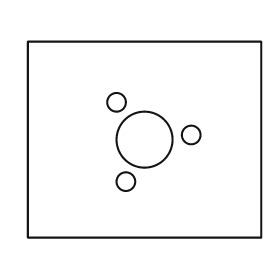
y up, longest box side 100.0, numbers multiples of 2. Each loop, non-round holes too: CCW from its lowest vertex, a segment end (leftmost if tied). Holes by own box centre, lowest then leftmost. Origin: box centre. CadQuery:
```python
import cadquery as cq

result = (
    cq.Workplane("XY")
    .moveTo(-50.0, -42.0)
    .lineTo(50.0, -42.0)
    .lineTo(50.0, 42.0)
    .lineTo(-50.0, 42.0)
    .close()
    .moveTo(-8.0, -18.0)
    .circle(4.0)
    .moveTo(0.0, 0.0)
    .circle(12.0)
    .moveTo(20.0, 2.0)
    .circle(4.0)
    .moveTo(-12.0, 16.0)
    .circle(4.0)
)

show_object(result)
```